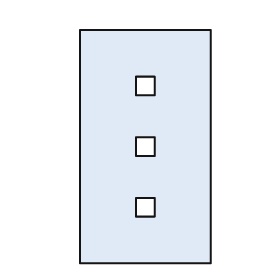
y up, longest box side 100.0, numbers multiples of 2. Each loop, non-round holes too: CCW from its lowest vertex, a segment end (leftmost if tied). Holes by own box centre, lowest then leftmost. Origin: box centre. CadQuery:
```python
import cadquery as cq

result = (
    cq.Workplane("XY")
    .moveTo(-28.0, -50.0)
    .lineTo(28.0, -50.0)
    .lineTo(28.0, 50.0)
    .lineTo(-28.0, 50.0)
    .close()
    .moveTo(-4.0, -30.0)
    .lineTo(4.0, -30.0)
    .lineTo(4.0, -22.0)
    .lineTo(-4.0, -22.0)
    .close()
    .moveTo(-4.0, -4.0)
    .lineTo(4.0, -4.0)
    .lineTo(4.0, 4.0)
    .lineTo(-4.0, 4.0)
    .close()
    .moveTo(-4.0, 22.0)
    .lineTo(4.0, 22.0)
    .lineTo(4.0, 30.0)
    .lineTo(-4.0, 30.0)
    .close()
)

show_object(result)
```